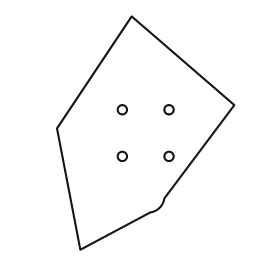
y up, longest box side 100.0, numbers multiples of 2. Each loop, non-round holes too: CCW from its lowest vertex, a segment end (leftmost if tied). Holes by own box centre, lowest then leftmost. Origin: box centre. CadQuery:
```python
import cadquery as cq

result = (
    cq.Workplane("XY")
    .moveTo(-28.0, -50.0)
    .lineTo(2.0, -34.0)
    .threePointArc((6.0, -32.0), (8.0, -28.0))
    .lineTo(38.0, 12.0)
    .lineTo(-6.0, 50.0)
    .lineTo(-38.0, 2.0)
    .close()
    .moveTo(-10.0, -10.0)
    .circle(2.0)
    .moveTo(10.0, -10.0)
    .circle(2.0)
    .moveTo(-10.0, 10.0)
    .circle(2.0)
    .moveTo(10.0, 10.0)
    .circle(2.0)
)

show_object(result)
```